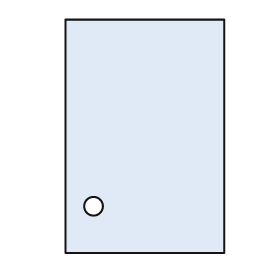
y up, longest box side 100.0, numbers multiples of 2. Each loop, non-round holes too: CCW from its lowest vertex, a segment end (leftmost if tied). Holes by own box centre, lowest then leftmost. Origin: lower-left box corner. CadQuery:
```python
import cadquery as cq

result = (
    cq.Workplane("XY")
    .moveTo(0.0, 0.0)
    .lineTo(68.0, 0.0)
    .lineTo(68.0, 100.0)
    .lineTo(0.0, 100.0)
    .close()
    .moveTo(12.0, 20.0)
    .circle(4.0)
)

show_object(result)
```